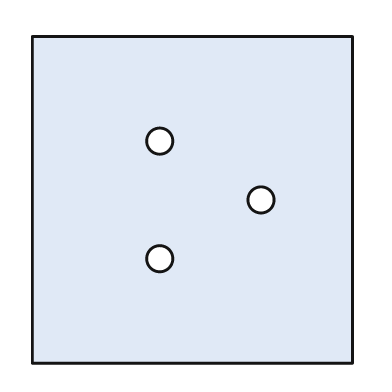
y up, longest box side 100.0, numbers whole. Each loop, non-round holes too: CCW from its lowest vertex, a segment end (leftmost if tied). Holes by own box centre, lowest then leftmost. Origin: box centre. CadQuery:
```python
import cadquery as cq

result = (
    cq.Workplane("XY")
    .moveTo(-49.0, -50.0)
    .lineTo(49.0, -50.0)
    .lineTo(49.0, 50.0)
    .lineTo(-49.0, 50.0)
    .close()
    .moveTo(-10.0, -18.0)
    .circle(4.0)
    .moveTo(21.0, 0.0)
    .circle(4.0)
    .moveTo(-10.0, 18.0)
    .circle(4.0)
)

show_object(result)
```